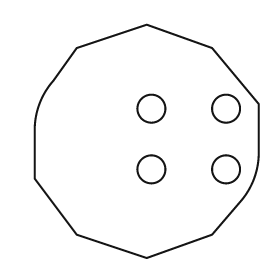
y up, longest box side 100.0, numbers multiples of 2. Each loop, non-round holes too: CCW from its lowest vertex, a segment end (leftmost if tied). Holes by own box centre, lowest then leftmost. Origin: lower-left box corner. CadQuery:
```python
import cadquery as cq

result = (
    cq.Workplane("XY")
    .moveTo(48.0, 0.0)
    .lineTo(76.0, 10.0)
    .lineTo(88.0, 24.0)
    .threePointArc((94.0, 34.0), (96.0, 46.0))
    .lineTo(96.0, 66.0)
    .lineTo(76.0, 90.0)
    .lineTo(48.0, 100.0)
    .lineTo(18.0, 90.0)
    .lineTo(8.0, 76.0)
    .threePointArc((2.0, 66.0), (0.0, 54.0))
    .lineTo(0.0, 34.0)
    .lineTo(18.0, 10.0)
    .close()
    .moveTo(50.0, 38.0)
    .circle(6.0)
    .moveTo(82.0, 38.0)
    .circle(6.0)
    .moveTo(50.0, 64.0)
    .circle(6.0)
    .moveTo(82.0, 64.0)
    .circle(6.0)
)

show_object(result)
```